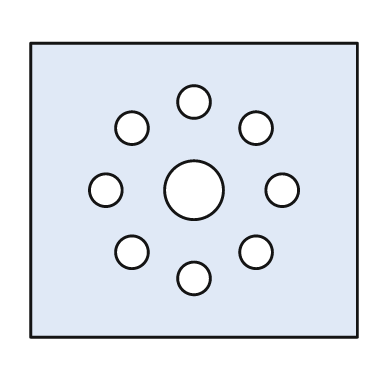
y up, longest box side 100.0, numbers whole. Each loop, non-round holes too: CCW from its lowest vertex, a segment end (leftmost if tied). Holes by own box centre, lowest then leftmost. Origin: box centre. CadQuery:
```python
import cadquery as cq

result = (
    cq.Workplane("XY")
    .moveTo(-50.0, -45.0)
    .lineTo(50.0, -45.0)
    .lineTo(50.0, 45.0)
    .lineTo(-50.0, 45.0)
    .close()
    .moveTo(0.0, -27.0)
    .circle(5.0)
    .moveTo(-19.0, -19.0)
    .circle(5.0)
    .moveTo(19.0, -19.0)
    .circle(5.0)
    .moveTo(-27.0, 0.0)
    .circle(5.0)
    .moveTo(0.0, 0.0)
    .circle(9.0)
    .moveTo(27.0, 0.0)
    .circle(5.0)
    .moveTo(-19.0, 19.0)
    .circle(5.0)
    .moveTo(19.0, 19.0)
    .circle(5.0)
    .moveTo(0.0, 27.0)
    .circle(5.0)
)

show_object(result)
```